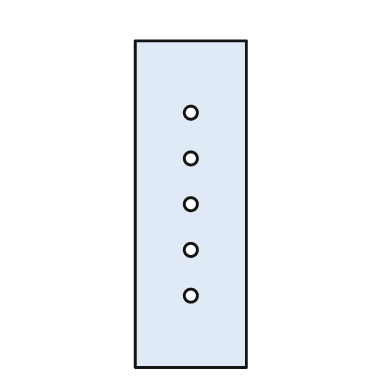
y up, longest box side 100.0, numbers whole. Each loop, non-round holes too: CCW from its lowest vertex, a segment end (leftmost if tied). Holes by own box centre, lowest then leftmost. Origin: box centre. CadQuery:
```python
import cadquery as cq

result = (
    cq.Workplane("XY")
    .moveTo(-17.0, -50.0)
    .lineTo(17.0, -50.0)
    .lineTo(17.0, 50.0)
    .lineTo(-17.0, 50.0)
    .close()
    .moveTo(0.0, -28.0)
    .circle(2.0)
    .moveTo(0.0, -14.0)
    .circle(2.0)
    .moveTo(0.0, 0.0)
    .circle(2.0)
    .moveTo(0.0, 14.0)
    .circle(2.0)
    .moveTo(0.0, 28.0)
    .circle(2.0)
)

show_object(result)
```